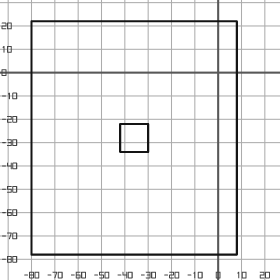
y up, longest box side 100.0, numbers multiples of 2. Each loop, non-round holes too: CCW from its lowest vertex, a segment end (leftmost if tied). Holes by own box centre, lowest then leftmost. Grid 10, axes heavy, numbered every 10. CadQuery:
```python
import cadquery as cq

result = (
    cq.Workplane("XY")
    .moveTo(-80.0, -78.0)
    .lineTo(8.0, -78.0)
    .lineTo(8.0, 22.0)
    .lineTo(-80.0, 22.0)
    .close()
    .moveTo(-42.0, -34.0)
    .lineTo(-30.0, -34.0)
    .lineTo(-30.0, -22.0)
    .lineTo(-42.0, -22.0)
    .close()
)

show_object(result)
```